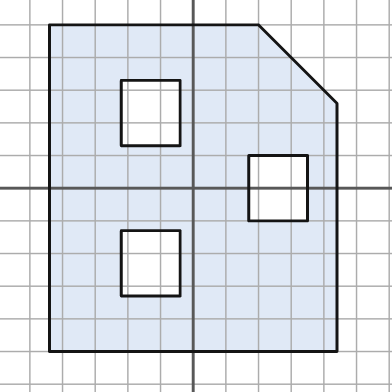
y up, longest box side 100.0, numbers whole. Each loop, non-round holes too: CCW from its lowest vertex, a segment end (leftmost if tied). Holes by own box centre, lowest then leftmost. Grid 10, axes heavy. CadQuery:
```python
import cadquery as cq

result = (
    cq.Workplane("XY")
    .moveTo(-44.0, -50.0)
    .lineTo(44.0, -50.0)
    .lineTo(44.0, 26.0)
    .lineTo(20.0, 50.0)
    .lineTo(-44.0, 50.0)
    .close()
    .moveTo(-22.0, -33.0)
    .lineTo(-4.0, -33.0)
    .lineTo(-4.0, -13.0)
    .lineTo(-22.0, -13.0)
    .close()
    .moveTo(17.0, -10.0)
    .lineTo(35.0, -10.0)
    .lineTo(35.0, 10.0)
    .lineTo(17.0, 10.0)
    .close()
    .moveTo(-22.0, 13.0)
    .lineTo(-4.0, 13.0)
    .lineTo(-4.0, 33.0)
    .lineTo(-22.0, 33.0)
    .close()
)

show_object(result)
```